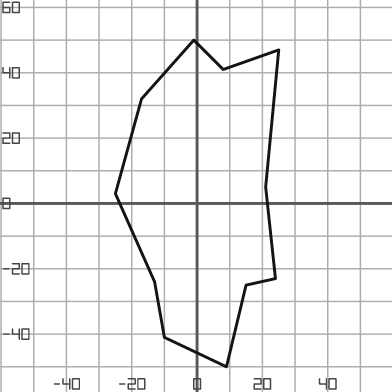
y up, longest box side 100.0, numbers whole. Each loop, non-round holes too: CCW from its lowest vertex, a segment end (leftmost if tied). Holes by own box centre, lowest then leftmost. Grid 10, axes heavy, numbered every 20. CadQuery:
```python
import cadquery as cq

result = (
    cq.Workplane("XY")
    .moveTo(9.0, -50.0)
    .lineTo(15.0, -25.0)
    .lineTo(24.0, -23.0)
    .lineTo(21.0, 5.0)
    .lineTo(25.0, 47.0)
    .lineTo(8.0, 41.0)
    .lineTo(-1.0, 50.0)
    .lineTo(-17.0, 32.0)
    .lineTo(-25.0, 3.0)
    .lineTo(-13.0, -24.0)
    .lineTo(-10.0, -41.0)
    .close()
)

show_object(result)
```